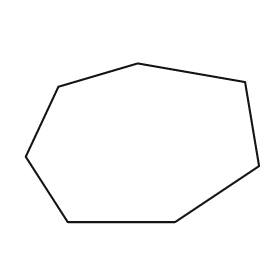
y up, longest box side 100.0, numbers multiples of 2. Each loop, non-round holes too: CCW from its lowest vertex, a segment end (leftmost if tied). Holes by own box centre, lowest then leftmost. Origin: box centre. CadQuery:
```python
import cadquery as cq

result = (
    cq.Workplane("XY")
    .moveTo(-32.0, -34.0)
    .lineTo(14.0, -34.0)
    .lineTo(50.0, -10.0)
    .lineTo(44.0, 26.0)
    .lineTo(-2.0, 34.0)
    .lineTo(-36.0, 24.0)
    .lineTo(-50.0, -6.0)
    .close()
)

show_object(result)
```